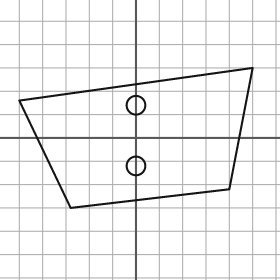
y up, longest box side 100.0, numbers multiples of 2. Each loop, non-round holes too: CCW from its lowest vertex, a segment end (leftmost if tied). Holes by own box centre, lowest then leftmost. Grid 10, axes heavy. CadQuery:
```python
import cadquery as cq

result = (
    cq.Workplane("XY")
    .moveTo(-28.0, -30.0)
    .lineTo(40.0, -22.0)
    .lineTo(50.0, 30.0)
    .lineTo(-50.0, 16.0)
    .close()
    .moveTo(0.0, -12.0)
    .circle(4.0)
    .moveTo(0.0, 14.0)
    .circle(4.0)
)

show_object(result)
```